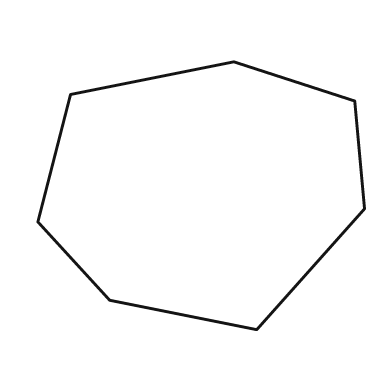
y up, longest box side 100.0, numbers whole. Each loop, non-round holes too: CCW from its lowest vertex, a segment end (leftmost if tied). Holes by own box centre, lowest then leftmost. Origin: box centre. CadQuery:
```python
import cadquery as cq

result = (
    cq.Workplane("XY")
    .moveTo(17.0, -41.0)
    .lineTo(50.0, -4.0)
    .lineTo(47.0, 29.0)
    .lineTo(10.0, 41.0)
    .lineTo(-40.0, 31.0)
    .lineTo(-50.0, -8.0)
    .lineTo(-28.0, -32.0)
    .close()
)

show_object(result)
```